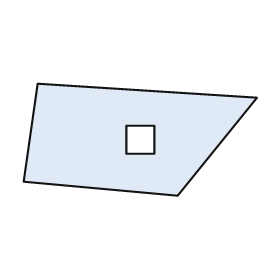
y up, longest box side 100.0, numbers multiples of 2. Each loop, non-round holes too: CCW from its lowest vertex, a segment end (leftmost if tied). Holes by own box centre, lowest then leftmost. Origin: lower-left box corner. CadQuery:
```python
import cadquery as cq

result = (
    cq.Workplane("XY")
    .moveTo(66.0, 0.0)
    .lineTo(100.0, 42.0)
    .lineTo(6.0, 48.0)
    .lineTo(0.0, 6.0)
    .close()
    .moveTo(44.0, 18.0)
    .lineTo(56.0, 18.0)
    .lineTo(56.0, 30.0)
    .lineTo(44.0, 30.0)
    .close()
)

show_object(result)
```